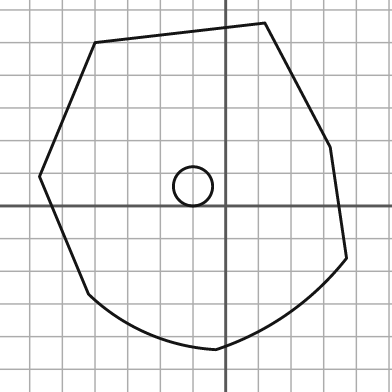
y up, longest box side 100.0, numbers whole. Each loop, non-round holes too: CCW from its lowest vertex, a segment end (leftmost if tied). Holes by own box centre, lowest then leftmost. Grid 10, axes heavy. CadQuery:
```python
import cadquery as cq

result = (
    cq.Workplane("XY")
    .moveTo(-3.0, -44.0)
    .threePointArc((19.0, -33.0), (37.0, -16.0))
    .lineTo(32.0, 18.0)
    .lineTo(12.0, 56.0)
    .lineTo(-40.0, 50.0)
    .lineTo(-57.0, 9.0)
    .lineTo(-42.0, -27.0)
    .threePointArc((-24.0, -39.0), (-3.0, -44.0))
    .close()
    .moveTo(-10.0, 6.0)
    .circle(6.0)
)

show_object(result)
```